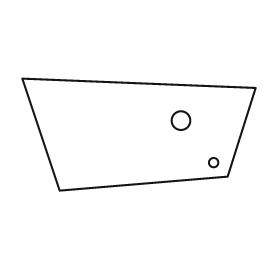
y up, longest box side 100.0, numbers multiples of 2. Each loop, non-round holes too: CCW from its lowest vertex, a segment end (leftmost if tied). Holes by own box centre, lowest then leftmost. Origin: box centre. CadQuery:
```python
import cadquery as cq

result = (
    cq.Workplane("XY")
    .moveTo(-34.0, -24.0)
    .lineTo(38.0, -18.0)
    .lineTo(50.0, 20.0)
    .lineTo(-50.0, 24.0)
    .close()
    .moveTo(32.0, -12.0)
    .circle(2.0)
    .moveTo(18.0, 6.0)
    .circle(4.0)
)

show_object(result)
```